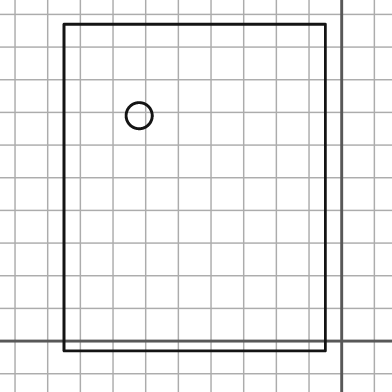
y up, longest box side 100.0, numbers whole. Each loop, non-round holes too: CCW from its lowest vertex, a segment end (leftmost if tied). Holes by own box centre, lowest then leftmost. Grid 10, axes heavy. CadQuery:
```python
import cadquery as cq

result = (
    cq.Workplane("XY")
    .moveTo(-85.0, -3.0)
    .lineTo(-5.0, -3.0)
    .lineTo(-5.0, 97.0)
    .lineTo(-85.0, 97.0)
    .close()
    .moveTo(-62.0, 69.0)
    .circle(4.0)
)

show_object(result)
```